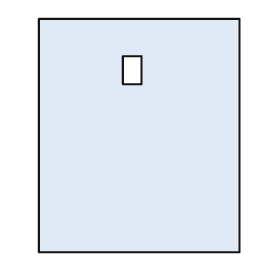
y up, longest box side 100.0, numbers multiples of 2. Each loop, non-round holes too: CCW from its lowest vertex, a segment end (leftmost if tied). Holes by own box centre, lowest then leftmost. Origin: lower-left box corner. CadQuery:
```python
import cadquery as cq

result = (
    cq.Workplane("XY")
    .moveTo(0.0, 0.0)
    .lineTo(86.0, 0.0)
    .lineTo(86.0, 100.0)
    .lineTo(0.0, 100.0)
    .close()
    .moveTo(36.0, 72.0)
    .lineTo(44.0, 72.0)
    .lineTo(44.0, 84.0)
    .lineTo(36.0, 84.0)
    .close()
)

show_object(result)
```